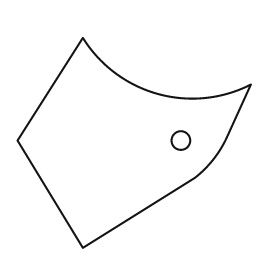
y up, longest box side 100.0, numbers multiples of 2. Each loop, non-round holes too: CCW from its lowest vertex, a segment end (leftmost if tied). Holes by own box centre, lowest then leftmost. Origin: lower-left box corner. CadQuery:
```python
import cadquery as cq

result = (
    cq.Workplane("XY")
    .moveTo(28.0, 0.0)
    .lineTo(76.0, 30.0)
    .threePointArc((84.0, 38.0), (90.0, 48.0))
    .lineTo(100.0, 70.0)
    .threePointArc((60.0, 66.0), (28.0, 90.0))
    .lineTo(0.0, 46.0)
    .close()
    .moveTo(70.0, 46.0)
    .circle(4.0)
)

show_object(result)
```